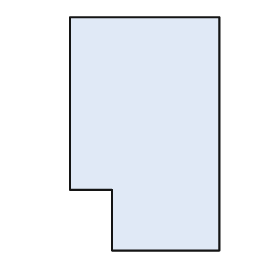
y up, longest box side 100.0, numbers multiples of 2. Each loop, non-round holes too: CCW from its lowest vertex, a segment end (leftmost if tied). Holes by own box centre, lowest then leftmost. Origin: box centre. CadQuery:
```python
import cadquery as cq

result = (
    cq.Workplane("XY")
    .moveTo(-14.0, -50.0)
    .lineTo(32.0, -50.0)
    .lineTo(32.0, 50.0)
    .lineTo(-32.0, 50.0)
    .lineTo(-32.0, -24.0)
    .lineTo(-14.0, -24.0)
    .close()
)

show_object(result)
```